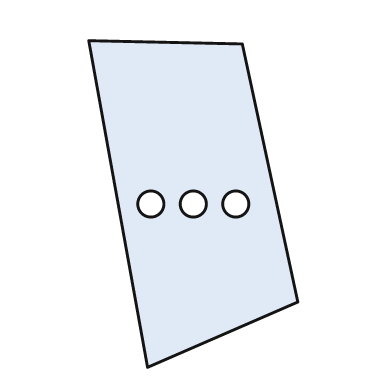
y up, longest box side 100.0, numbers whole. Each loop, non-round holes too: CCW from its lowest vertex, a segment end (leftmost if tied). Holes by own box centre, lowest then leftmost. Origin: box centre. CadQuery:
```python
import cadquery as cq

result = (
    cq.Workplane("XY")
    .moveTo(-14.0, -50.0)
    .lineTo(32.0, -30.0)
    .lineTo(15.0, 49.0)
    .lineTo(-32.0, 50.0)
    .close()
    .moveTo(-13.0, 0.0)
    .circle(4.0)
    .moveTo(0.0, 0.0)
    .circle(4.0)
    .moveTo(13.0, 0.0)
    .circle(4.0)
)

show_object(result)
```